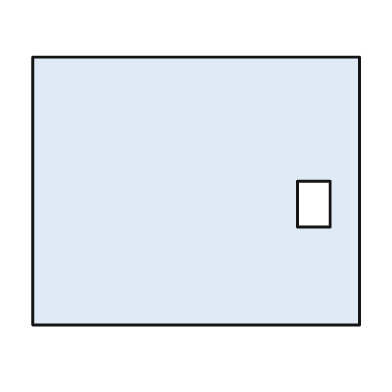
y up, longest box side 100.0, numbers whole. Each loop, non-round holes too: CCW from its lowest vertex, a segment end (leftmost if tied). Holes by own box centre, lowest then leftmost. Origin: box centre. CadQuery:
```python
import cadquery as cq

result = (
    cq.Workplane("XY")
    .moveTo(-50.0, -41.0)
    .lineTo(50.0, -41.0)
    .lineTo(50.0, 41.0)
    .lineTo(-50.0, 41.0)
    .close()
    .moveTo(31.0, -11.0)
    .lineTo(41.0, -11.0)
    .lineTo(41.0, 3.0)
    .lineTo(31.0, 3.0)
    .close()
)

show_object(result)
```